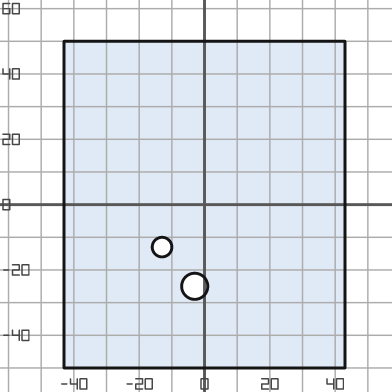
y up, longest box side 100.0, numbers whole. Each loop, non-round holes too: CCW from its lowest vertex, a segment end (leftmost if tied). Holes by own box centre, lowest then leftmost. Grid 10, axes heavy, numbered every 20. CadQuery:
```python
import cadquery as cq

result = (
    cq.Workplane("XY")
    .moveTo(-43.0, -50.0)
    .lineTo(43.0, -50.0)
    .lineTo(43.0, 50.0)
    .lineTo(-43.0, 50.0)
    .close()
    .moveTo(-3.0, -25.0)
    .circle(4.0)
    .moveTo(-13.0, -13.0)
    .circle(3.0)
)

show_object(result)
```